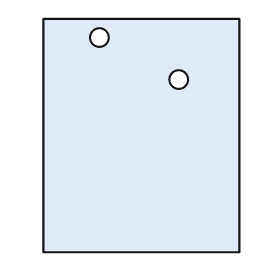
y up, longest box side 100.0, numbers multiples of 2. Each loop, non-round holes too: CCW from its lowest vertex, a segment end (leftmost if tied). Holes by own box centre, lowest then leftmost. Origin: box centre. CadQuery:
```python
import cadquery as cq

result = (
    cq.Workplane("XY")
    .moveTo(-42.0, -50.0)
    .lineTo(42.0, -50.0)
    .lineTo(42.0, 50.0)
    .lineTo(-42.0, 50.0)
    .close()
    .moveTo(16.0, 24.0)
    .circle(4.0)
    .moveTo(-18.0, 42.0)
    .circle(4.0)
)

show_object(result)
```